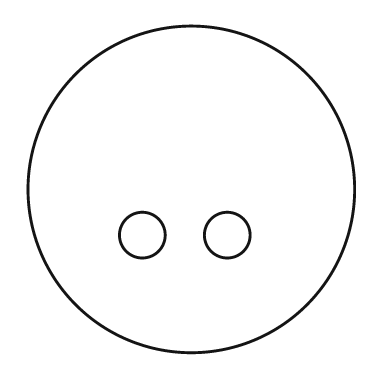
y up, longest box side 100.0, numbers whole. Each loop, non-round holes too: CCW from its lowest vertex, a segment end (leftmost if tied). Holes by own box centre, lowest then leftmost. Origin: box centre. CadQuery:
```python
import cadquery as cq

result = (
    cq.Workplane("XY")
    .moveTo(0.0, 0.0)
    .circle(50.0)
    .moveTo(-15.0, -14.0)
    .circle(7.0)
    .moveTo(11.0, -14.0)
    .circle(7.0)
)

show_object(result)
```